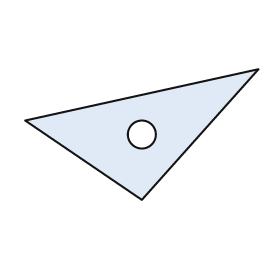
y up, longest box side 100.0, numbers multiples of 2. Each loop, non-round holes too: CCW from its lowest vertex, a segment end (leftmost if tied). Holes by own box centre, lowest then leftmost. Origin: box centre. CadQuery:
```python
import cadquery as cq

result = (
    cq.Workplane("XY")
    .moveTo(0.0, -28.0)
    .lineTo(50.0, 28.0)
    .lineTo(-50.0, 6.0)
    .close()
    .moveTo(0.0, 0.0)
    .circle(6.0)
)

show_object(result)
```